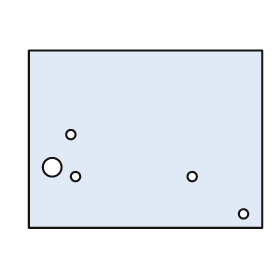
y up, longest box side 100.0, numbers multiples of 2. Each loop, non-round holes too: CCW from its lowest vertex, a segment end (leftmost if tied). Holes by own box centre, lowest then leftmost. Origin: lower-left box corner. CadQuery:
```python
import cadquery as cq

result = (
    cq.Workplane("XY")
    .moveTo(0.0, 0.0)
    .lineTo(100.0, 0.0)
    .lineTo(100.0, 76.0)
    .lineTo(0.0, 76.0)
    .close()
    .moveTo(92.0, 6.0)
    .circle(2.0)
    .moveTo(20.0, 22.0)
    .circle(2.0)
    .moveTo(70.0, 22.0)
    .circle(2.0)
    .moveTo(10.0, 26.0)
    .circle(4.0)
    .moveTo(18.0, 40.0)
    .circle(2.0)
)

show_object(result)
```